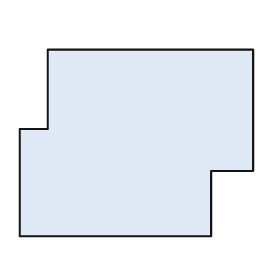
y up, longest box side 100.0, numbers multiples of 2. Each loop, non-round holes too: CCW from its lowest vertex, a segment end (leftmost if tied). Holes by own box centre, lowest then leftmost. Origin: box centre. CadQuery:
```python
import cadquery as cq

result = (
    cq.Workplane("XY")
    .moveTo(-50.0, -40.0)
    .lineTo(32.0, -40.0)
    .lineTo(32.0, -12.0)
    .lineTo(50.0, -12.0)
    .lineTo(50.0, 40.0)
    .lineTo(-38.0, 40.0)
    .lineTo(-38.0, 6.0)
    .lineTo(-50.0, 6.0)
    .close()
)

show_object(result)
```